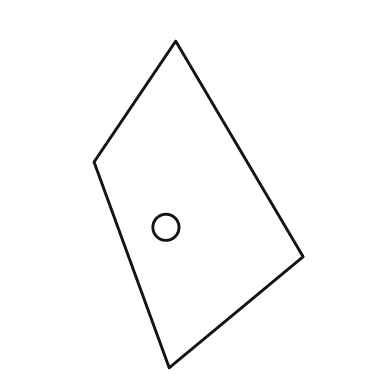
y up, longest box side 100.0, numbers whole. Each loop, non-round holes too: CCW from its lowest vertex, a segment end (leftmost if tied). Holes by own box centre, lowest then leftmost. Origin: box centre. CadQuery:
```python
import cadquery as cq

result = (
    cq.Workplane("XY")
    .moveTo(-9.0, -50.0)
    .lineTo(32.0, -16.0)
    .lineTo(-7.0, 50.0)
    .lineTo(-32.0, 13.0)
    .close()
    .moveTo(-10.0, -7.0)
    .circle(4.0)
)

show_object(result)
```